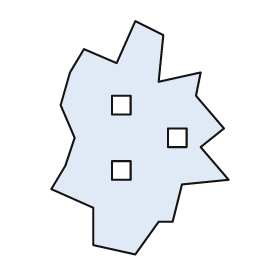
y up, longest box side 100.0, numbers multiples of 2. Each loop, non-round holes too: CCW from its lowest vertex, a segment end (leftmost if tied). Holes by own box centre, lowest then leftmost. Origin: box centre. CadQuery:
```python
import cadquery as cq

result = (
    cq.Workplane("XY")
    .moveTo(-2.0, -50.0)
    .lineTo(8.0, -36.0)
    .lineTo(14.0, -36.0)
    .lineTo(18.0, -20.0)
    .lineTo(38.0, -18.0)
    .lineTo(26.0, -4.0)
    .lineTo(36.0, 4.0)
    .lineTo(24.0, 18.0)
    .lineTo(26.0, 28.0)
    .lineTo(8.0, 24.0)
    .lineTo(10.0, 44.0)
    .lineTo(-2.0, 50.0)
    .lineTo(-10.0, 32.0)
    .lineTo(-24.0, 38.0)
    .lineTo(-30.0, 28.0)
    .lineTo(-34.0, 14.0)
    .lineTo(-28.0, 0.0)
    .lineTo(-32.0, -12.0)
    .lineTo(-38.0, -22.0)
    .lineTo(-20.0, -30.0)
    .lineTo(-20.0, -46.0)
    .close()
    .moveTo(-12.0, -18.0)
    .lineTo(-4.0, -18.0)
    .lineTo(-4.0, -10.0)
    .lineTo(-12.0, -10.0)
    .close()
    .moveTo(12.0, -4.0)
    .lineTo(20.0, -4.0)
    .lineTo(20.0, 4.0)
    .lineTo(12.0, 4.0)
    .close()
    .moveTo(-12.0, 10.0)
    .lineTo(-4.0, 10.0)
    .lineTo(-4.0, 18.0)
    .lineTo(-12.0, 18.0)
    .close()
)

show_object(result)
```